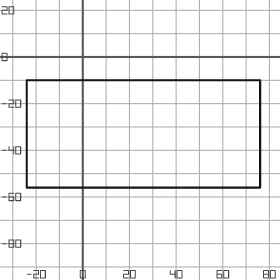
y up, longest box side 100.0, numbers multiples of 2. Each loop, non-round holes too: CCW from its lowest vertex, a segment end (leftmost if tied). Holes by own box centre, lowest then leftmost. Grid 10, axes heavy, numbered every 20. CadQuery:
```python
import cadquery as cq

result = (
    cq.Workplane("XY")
    .moveTo(-24.0, -56.0)
    .lineTo(76.0, -56.0)
    .lineTo(76.0, -10.0)
    .lineTo(-24.0, -10.0)
    .close()
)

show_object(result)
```